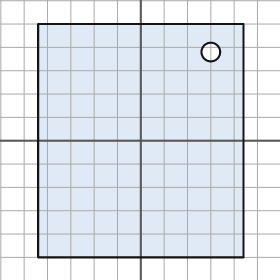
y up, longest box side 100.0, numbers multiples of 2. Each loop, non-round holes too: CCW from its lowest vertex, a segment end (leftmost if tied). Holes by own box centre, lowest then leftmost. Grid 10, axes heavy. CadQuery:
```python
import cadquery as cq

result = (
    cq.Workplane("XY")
    .moveTo(-44.0, -50.0)
    .lineTo(44.0, -50.0)
    .lineTo(44.0, 50.0)
    .lineTo(-44.0, 50.0)
    .close()
    .moveTo(30.0, 38.0)
    .circle(4.0)
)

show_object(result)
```